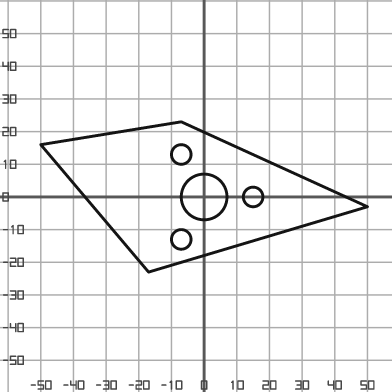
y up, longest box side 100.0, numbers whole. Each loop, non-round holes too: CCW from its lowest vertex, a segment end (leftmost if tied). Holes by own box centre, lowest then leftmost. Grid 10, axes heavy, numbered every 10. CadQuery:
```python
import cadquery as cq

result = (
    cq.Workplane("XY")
    .moveTo(-17.0, -23.0)
    .lineTo(50.0, -3.0)
    .lineTo(-7.0, 23.0)
    .lineTo(-50.0, 16.0)
    .close()
    .moveTo(-7.0, -13.0)
    .circle(3.0)
    .moveTo(0.0, 0.0)
    .circle(7.0)
    .moveTo(15.0, 0.0)
    .circle(3.0)
    .moveTo(-7.0, 13.0)
    .circle(3.0)
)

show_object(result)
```